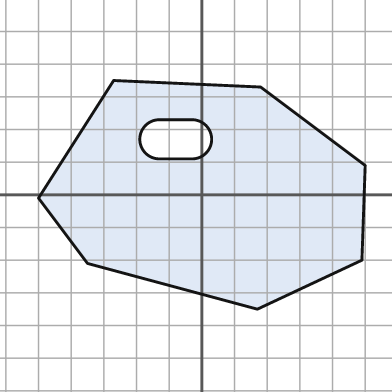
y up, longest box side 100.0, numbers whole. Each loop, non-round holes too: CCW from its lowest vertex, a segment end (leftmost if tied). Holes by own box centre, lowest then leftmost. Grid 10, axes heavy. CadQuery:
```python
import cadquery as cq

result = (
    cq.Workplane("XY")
    .moveTo(17.0, -35.0)
    .lineTo(49.0, -20.0)
    .lineTo(50.0, 9.0)
    .lineTo(18.0, 33.0)
    .lineTo(-27.0, 35.0)
    .lineTo(-50.0, -1.0)
    .lineTo(-35.0, -21.0)
    .close()
    .moveTo(-13.0, 11.0)
    .lineTo(-3.0, 11.0)
    .threePointArc((3.0, 17.0), (-3.0, 23.0))
    .lineTo(-13.0, 23.0)
    .threePointArc((-19.0, 17.0), (-13.0, 11.0))
    .close()
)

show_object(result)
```